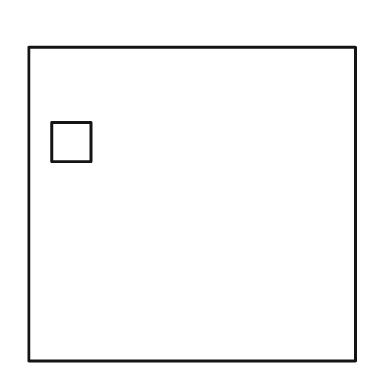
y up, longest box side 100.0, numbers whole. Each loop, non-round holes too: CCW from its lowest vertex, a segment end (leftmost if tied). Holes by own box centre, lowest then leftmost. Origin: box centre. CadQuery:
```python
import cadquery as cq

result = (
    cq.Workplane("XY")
    .moveTo(-50.0, -48.0)
    .lineTo(50.0, -48.0)
    .lineTo(50.0, 48.0)
    .lineTo(-50.0, 48.0)
    .close()
    .moveTo(-43.0, 13.0)
    .lineTo(-31.0, 13.0)
    .lineTo(-31.0, 25.0)
    .lineTo(-43.0, 25.0)
    .close()
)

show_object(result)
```